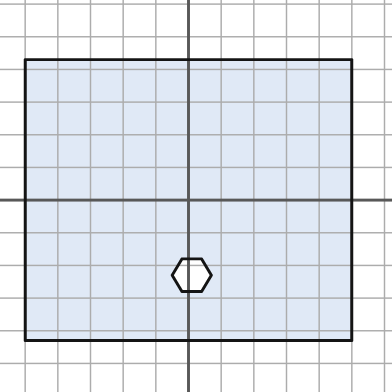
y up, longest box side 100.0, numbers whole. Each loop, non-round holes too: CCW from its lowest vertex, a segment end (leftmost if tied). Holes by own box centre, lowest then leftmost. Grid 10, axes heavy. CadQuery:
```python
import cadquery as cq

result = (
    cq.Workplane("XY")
    .moveTo(-50.0, -43.0)
    .lineTo(50.0, -43.0)
    .lineTo(50.0, 43.0)
    .lineTo(-50.0, 43.0)
    .close()
    .moveTo(-2.0, -28.0)
    .lineTo(4.0, -28.0)
    .lineTo(7.0, -23.0)
    .lineTo(4.0, -18.0)
    .lineTo(-2.0, -18.0)
    .lineTo(-5.0, -23.0)
    .close()
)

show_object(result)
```